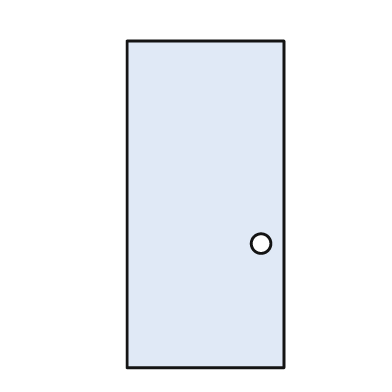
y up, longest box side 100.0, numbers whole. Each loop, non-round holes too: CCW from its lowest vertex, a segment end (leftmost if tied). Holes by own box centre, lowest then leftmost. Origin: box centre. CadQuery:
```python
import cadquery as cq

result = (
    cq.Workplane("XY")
    .moveTo(-24.0, -50.0)
    .lineTo(24.0, -50.0)
    .lineTo(24.0, 50.0)
    .lineTo(-24.0, 50.0)
    .close()
    .moveTo(17.0, -12.0)
    .circle(3.0)
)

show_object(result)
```